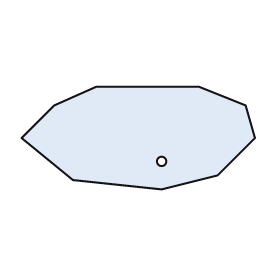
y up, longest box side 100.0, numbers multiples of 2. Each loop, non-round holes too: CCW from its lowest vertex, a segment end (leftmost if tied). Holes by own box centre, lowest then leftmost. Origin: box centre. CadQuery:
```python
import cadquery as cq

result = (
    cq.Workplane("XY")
    .moveTo(10.0, -22.0)
    .lineTo(34.0, -16.0)
    .lineTo(50.0, 0.0)
    .lineTo(46.0, 14.0)
    .lineTo(26.0, 22.0)
    .lineTo(-18.0, 22.0)
    .lineTo(-36.0, 14.0)
    .lineTo(-50.0, 0.0)
    .lineTo(-28.0, -18.0)
    .close()
    .moveTo(10.0, -10.0)
    .circle(2.0)
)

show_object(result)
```